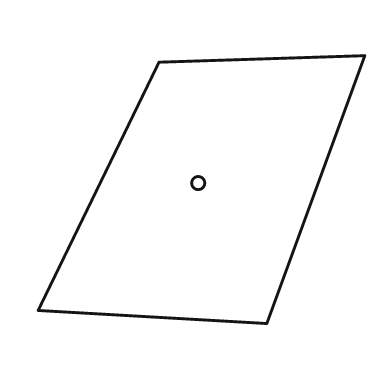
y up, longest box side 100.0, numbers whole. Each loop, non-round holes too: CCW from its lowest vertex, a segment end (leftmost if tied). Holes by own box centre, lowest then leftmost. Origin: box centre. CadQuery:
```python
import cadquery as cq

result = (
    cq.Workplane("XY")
    .moveTo(20.0, -41.0)
    .lineTo(50.0, 41.0)
    .lineTo(-13.0, 39.0)
    .lineTo(-50.0, -37.0)
    .close()
    .moveTo(-1.0, 2.0)
    .circle(2.0)
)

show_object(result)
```